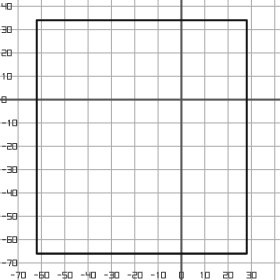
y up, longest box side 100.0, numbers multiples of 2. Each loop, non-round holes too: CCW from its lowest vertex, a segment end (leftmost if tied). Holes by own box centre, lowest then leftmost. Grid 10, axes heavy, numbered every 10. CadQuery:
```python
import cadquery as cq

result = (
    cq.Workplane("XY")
    .moveTo(-62.0, -66.0)
    .lineTo(28.0, -66.0)
    .lineTo(28.0, 34.0)
    .lineTo(-62.0, 34.0)
    .close()
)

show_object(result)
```